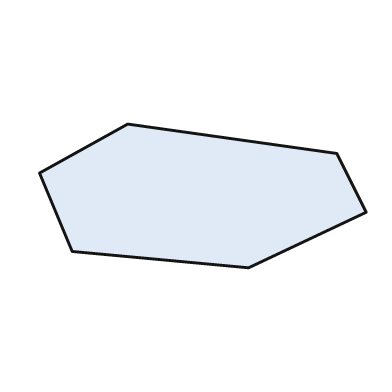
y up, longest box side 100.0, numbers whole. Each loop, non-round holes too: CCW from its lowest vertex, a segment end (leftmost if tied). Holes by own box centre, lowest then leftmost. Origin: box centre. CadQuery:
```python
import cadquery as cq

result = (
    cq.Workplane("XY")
    .moveTo(14.0, -22.0)
    .lineTo(50.0, -5.0)
    .lineTo(41.0, 13.0)
    .lineTo(-23.0, 22.0)
    .lineTo(-50.0, 7.0)
    .lineTo(-40.0, -17.0)
    .close()
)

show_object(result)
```